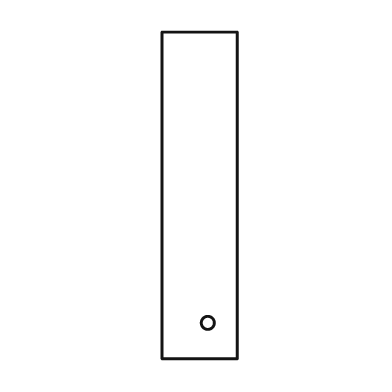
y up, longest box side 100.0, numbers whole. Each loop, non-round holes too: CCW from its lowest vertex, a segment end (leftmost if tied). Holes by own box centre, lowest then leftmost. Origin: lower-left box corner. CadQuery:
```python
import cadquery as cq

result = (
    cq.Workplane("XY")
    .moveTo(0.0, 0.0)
    .lineTo(23.0, 0.0)
    .lineTo(23.0, 100.0)
    .lineTo(0.0, 100.0)
    .close()
    .moveTo(14.0, 11.0)
    .circle(2.0)
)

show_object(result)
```